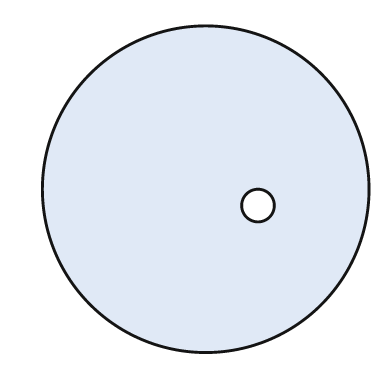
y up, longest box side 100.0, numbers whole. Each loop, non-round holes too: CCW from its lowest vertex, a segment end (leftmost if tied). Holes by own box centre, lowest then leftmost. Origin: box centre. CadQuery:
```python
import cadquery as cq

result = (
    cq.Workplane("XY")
    .moveTo(0.0, 0.0)
    .circle(50.0)
    .moveTo(16.0, -5.0)
    .circle(5.0)
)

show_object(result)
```